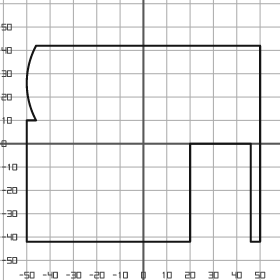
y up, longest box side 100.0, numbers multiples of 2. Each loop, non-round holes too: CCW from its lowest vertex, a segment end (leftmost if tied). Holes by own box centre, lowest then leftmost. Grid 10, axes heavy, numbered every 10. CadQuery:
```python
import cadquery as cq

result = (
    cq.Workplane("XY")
    .moveTo(-50.0, -42.0)
    .lineTo(20.0, -42.0)
    .lineTo(20.0, 0.0)
    .lineTo(46.0, 0.0)
    .lineTo(46.0, -42.0)
    .lineTo(50.0, -42.0)
    .lineTo(50.0, 42.0)
    .lineTo(-46.0, 42.0)
    .threePointArc((-50.0, 26.0), (-46.0, 10.0))
    .lineTo(-50.0, 10.0)
    .close()
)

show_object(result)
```